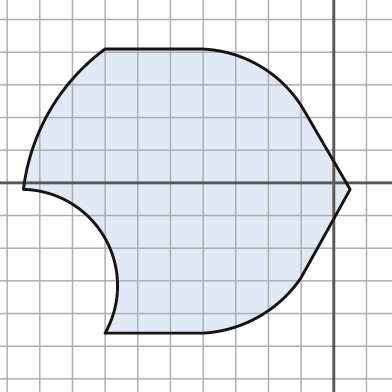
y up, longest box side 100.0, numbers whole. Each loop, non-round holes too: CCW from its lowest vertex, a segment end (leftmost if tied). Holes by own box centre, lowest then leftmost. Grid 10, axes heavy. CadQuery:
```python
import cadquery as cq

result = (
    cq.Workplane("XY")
    .moveTo(-70.0, -46.0)
    .lineTo(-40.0, -46.0)
    .threePointArc((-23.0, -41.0), (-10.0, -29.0))
    .lineTo(5.0, -2.0)
    .lineTo(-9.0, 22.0)
    .threePointArc((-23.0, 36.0), (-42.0, 41.0))
    .lineTo(-70.0, 41.0)
    .threePointArc((-87.0, 22.0), (-95.0, -2.0))
    .threePointArc((-70.0, -17.0), (-70.0, -46.0))
    .close()
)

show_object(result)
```